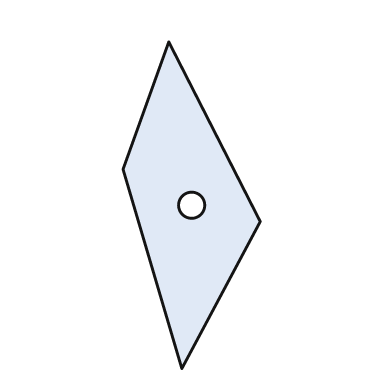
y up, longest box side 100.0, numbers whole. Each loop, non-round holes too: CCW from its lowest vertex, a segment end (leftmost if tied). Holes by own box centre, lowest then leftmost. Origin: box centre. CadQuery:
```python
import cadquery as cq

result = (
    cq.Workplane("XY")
    .moveTo(-3.0, -50.0)
    .lineTo(21.0, -5.0)
    .lineTo(-7.0, 50.0)
    .lineTo(-21.0, 11.0)
    .close()
    .moveTo(0.0, 0.0)
    .circle(4.0)
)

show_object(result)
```